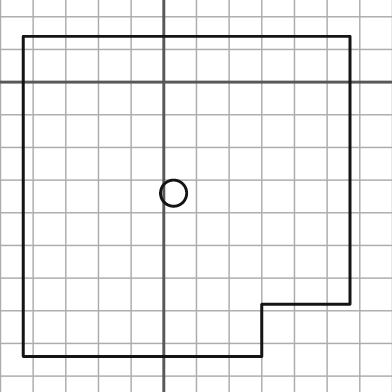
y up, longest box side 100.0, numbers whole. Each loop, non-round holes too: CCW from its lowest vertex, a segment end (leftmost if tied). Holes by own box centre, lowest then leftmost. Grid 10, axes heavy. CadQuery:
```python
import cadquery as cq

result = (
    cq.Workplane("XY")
    .moveTo(-43.0, -84.0)
    .lineTo(30.0, -84.0)
    .lineTo(30.0, -68.0)
    .lineTo(57.0, -68.0)
    .lineTo(57.0, 14.0)
    .lineTo(-43.0, 14.0)
    .close()
    .moveTo(3.0, -34.0)
    .circle(4.0)
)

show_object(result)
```